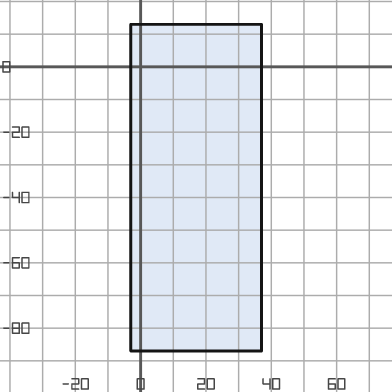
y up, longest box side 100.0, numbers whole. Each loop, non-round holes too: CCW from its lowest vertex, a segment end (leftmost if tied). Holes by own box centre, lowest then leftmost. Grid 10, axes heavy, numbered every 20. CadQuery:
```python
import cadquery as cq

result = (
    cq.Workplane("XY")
    .moveTo(-3.0, -87.0)
    .lineTo(37.0, -87.0)
    .lineTo(37.0, 13.0)
    .lineTo(-3.0, 13.0)
    .close()
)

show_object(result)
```